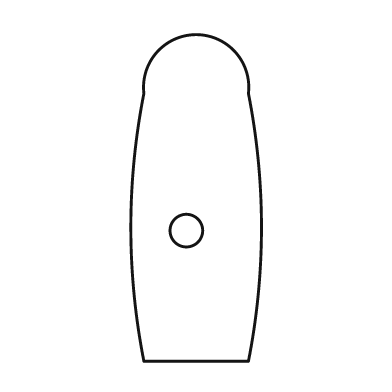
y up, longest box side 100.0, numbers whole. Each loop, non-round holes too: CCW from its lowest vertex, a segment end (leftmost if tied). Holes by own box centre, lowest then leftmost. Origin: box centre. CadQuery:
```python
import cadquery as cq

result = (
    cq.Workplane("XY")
    .moveTo(-16.0, -50.0)
    .lineTo(16.0, -50.0)
    .threePointArc((20.0, -9.0), (16.0, 32.0))
    .threePointArc((0.0, 50.0), (-16.0, 32.0))
    .threePointArc((-20.0, -9.0), (-16.0, -50.0))
    .close()
    .moveTo(-3.0, -10.0)
    .circle(5.0)
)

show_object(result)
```